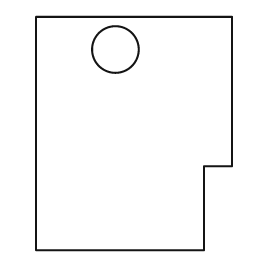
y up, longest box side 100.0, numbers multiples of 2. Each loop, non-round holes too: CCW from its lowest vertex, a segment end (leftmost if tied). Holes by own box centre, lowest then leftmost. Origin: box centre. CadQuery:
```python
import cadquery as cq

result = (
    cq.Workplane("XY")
    .moveTo(-42.0, -50.0)
    .lineTo(30.0, -50.0)
    .lineTo(30.0, -14.0)
    .lineTo(42.0, -14.0)
    .lineTo(42.0, 50.0)
    .lineTo(-42.0, 50.0)
    .close()
    .moveTo(-8.0, 36.0)
    .circle(10.0)
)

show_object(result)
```